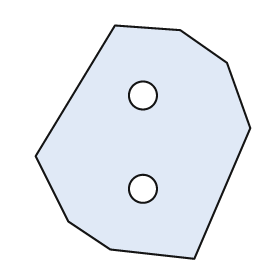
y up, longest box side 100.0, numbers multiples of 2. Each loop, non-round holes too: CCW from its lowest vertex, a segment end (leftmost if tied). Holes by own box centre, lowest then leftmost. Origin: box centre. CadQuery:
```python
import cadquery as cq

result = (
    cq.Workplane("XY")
    .moveTo(22.0, -50.0)
    .lineTo(46.0, 6.0)
    .lineTo(36.0, 34.0)
    .lineTo(16.0, 48.0)
    .lineTo(-12.0, 50.0)
    .lineTo(-46.0, -6.0)
    .lineTo(-32.0, -34.0)
    .lineTo(-14.0, -46.0)
    .close()
    .moveTo(0.0, -20.0)
    .circle(6.0)
    .moveTo(0.0, 20.0)
    .circle(6.0)
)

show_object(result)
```